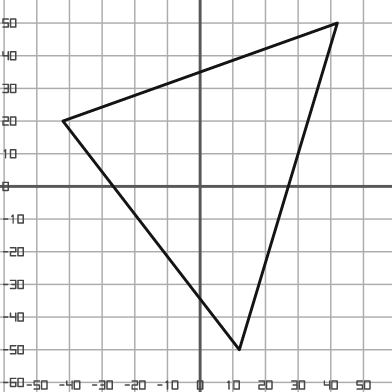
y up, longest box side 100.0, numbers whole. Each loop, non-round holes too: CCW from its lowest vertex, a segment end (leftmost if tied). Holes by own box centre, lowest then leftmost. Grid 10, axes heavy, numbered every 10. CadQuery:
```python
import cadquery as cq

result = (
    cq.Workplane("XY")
    .moveTo(12.0, -50.0)
    .lineTo(42.0, 50.0)
    .lineTo(-42.0, 20.0)
    .close()
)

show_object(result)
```